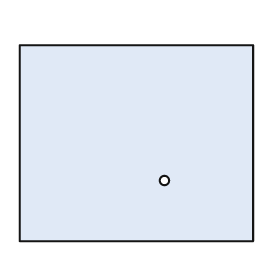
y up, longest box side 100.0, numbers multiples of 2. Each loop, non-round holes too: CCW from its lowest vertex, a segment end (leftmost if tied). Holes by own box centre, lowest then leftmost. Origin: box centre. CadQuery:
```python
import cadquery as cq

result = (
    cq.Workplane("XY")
    .moveTo(-50.0, -42.0)
    .lineTo(50.0, -42.0)
    .lineTo(50.0, 42.0)
    .lineTo(-50.0, 42.0)
    .close()
    .moveTo(12.0, -16.0)
    .circle(2.0)
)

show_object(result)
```